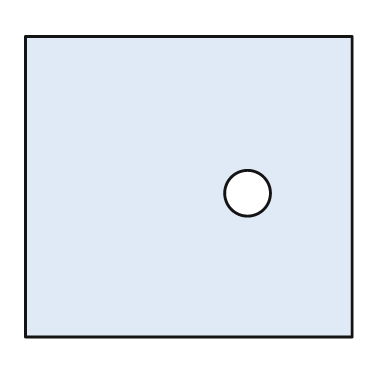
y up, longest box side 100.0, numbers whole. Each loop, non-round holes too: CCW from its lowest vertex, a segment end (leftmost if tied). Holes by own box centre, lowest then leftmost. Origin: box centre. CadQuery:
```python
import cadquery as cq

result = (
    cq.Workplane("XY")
    .moveTo(-50.0, -46.0)
    .lineTo(50.0, -46.0)
    .lineTo(50.0, 46.0)
    .lineTo(-50.0, 46.0)
    .close()
    .moveTo(18.0, -2.0)
    .circle(7.0)
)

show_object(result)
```